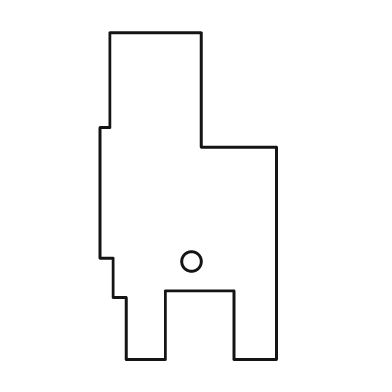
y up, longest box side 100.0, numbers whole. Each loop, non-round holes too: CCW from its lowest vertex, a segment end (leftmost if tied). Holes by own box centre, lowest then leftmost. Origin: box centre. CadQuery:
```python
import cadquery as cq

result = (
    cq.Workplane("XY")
    .moveTo(-19.0, -50.0)
    .lineTo(-7.0, -50.0)
    .lineTo(-7.0, -29.0)
    .lineTo(14.0, -29.0)
    .lineTo(14.0, -50.0)
    .lineTo(27.0, -50.0)
    .lineTo(27.0, 15.0)
    .lineTo(4.0, 15.0)
    .lineTo(4.0, 50.0)
    .lineTo(-24.0, 50.0)
    .lineTo(-24.0, 21.0)
    .lineTo(-27.0, 21.0)
    .lineTo(-27.0, -19.0)
    .lineTo(-23.0, -19.0)
    .lineTo(-23.0, -31.0)
    .lineTo(-19.0, -31.0)
    .close()
    .moveTo(1.0, -20.0)
    .circle(3.0)
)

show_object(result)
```